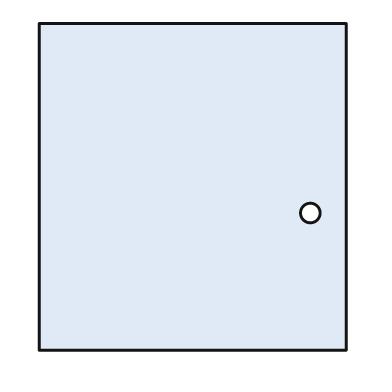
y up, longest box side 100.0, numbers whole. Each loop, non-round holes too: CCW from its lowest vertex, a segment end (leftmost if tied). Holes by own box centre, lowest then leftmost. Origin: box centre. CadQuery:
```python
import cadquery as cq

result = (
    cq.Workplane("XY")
    .moveTo(-47.0, -50.0)
    .lineTo(47.0, -50.0)
    .lineTo(47.0, 50.0)
    .lineTo(-47.0, 50.0)
    .close()
    .moveTo(36.0, -8.0)
    .circle(3.0)
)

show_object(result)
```